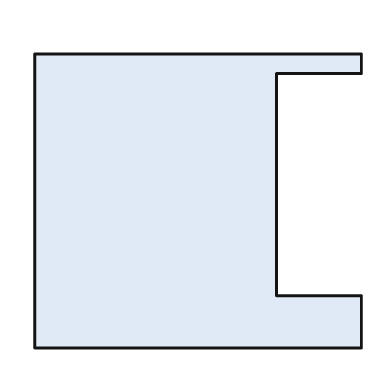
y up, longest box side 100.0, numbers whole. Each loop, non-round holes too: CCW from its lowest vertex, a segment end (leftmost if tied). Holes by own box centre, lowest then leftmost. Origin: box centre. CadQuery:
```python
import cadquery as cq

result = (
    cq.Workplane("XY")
    .moveTo(-50.0, -45.0)
    .lineTo(50.0, -45.0)
    .lineTo(50.0, -29.0)
    .lineTo(24.0, -29.0)
    .lineTo(24.0, 39.0)
    .lineTo(50.0, 39.0)
    .lineTo(50.0, 45.0)
    .lineTo(-50.0, 45.0)
    .close()
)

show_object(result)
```